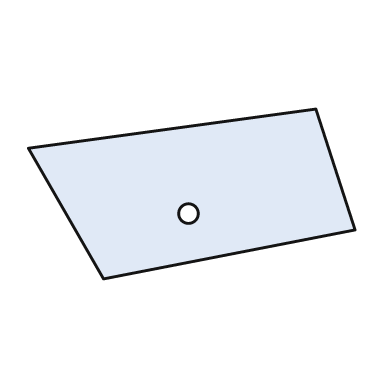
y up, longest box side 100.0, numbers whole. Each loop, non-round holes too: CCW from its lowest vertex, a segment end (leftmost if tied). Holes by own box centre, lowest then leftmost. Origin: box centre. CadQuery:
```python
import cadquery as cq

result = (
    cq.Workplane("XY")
    .moveTo(-27.0, -26.0)
    .lineTo(50.0, -11.0)
    .lineTo(38.0, 26.0)
    .lineTo(-50.0, 14.0)
    .close()
    .moveTo(-1.0, -6.0)
    .circle(3.0)
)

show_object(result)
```